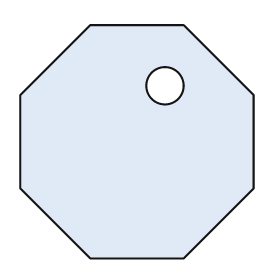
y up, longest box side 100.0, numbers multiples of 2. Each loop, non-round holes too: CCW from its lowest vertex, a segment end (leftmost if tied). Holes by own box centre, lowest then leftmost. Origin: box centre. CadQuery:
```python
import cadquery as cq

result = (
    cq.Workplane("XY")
    .moveTo(-20.0, -50.0)
    .lineTo(20.0, -50.0)
    .lineTo(50.0, -20.0)
    .lineTo(50.0, 20.0)
    .lineTo(20.0, 50.0)
    .lineTo(-20.0, 50.0)
    .lineTo(-50.0, 20.0)
    .lineTo(-50.0, -20.0)
    .close()
    .moveTo(12.0, 24.0)
    .circle(8.0)
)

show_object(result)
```